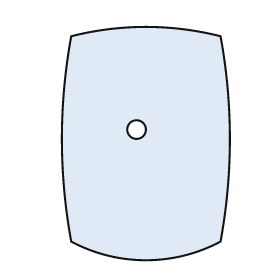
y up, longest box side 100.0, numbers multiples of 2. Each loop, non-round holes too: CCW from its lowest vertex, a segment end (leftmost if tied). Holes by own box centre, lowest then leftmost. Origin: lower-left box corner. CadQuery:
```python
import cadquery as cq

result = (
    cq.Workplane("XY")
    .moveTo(4.0, 8.0)
    .threePointArc((36.0, 0.0), (68.0, 8.0))
    .threePointArc((72.0, 52.0), (68.0, 96.0))
    .threePointArc((36.0, 100.0), (4.0, 96.0))
    .threePointArc((0.0, 52.0), (4.0, 8.0))
    .close()
    .moveTo(32.0, 56.0)
    .circle(4.0)
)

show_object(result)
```